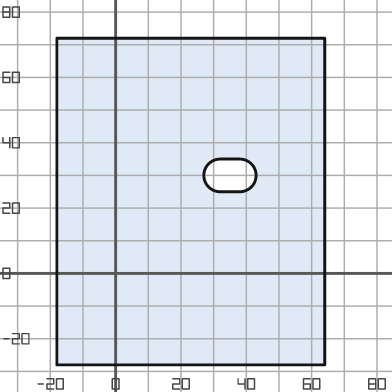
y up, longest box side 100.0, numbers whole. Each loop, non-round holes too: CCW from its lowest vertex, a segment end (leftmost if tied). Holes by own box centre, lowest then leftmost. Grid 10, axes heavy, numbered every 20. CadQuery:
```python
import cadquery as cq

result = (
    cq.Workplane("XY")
    .moveTo(-18.0, -28.0)
    .lineTo(64.0, -28.0)
    .lineTo(64.0, 72.0)
    .lineTo(-18.0, 72.0)
    .close()
    .moveTo(32.0, 25.0)
    .lineTo(38.0, 25.0)
    .threePointArc((43.0, 30.0), (38.0, 35.0))
    .lineTo(32.0, 35.0)
    .threePointArc((27.0, 30.0), (32.0, 25.0))
    .close()
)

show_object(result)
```